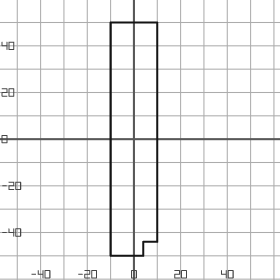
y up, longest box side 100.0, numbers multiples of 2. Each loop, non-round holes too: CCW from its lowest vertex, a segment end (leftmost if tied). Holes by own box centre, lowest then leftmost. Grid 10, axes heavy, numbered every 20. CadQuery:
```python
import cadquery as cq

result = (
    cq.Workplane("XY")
    .moveTo(-10.0, -50.0)
    .lineTo(4.0, -50.0)
    .lineTo(4.0, -44.0)
    .lineTo(10.0, -44.0)
    .lineTo(10.0, 50.0)
    .lineTo(-10.0, 50.0)
    .close()
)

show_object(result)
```